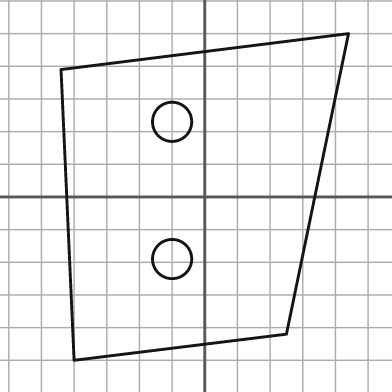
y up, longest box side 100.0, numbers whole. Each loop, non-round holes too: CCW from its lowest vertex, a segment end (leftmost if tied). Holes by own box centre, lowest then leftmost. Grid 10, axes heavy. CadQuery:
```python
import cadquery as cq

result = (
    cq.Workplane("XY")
    .moveTo(-40.0, -50.0)
    .lineTo(25.0, -42.0)
    .lineTo(44.0, 50.0)
    .lineTo(-44.0, 39.0)
    .close()
    .moveTo(-10.0, -19.0)
    .circle(6.0)
    .moveTo(-10.0, 23.0)
    .circle(6.0)
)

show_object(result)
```